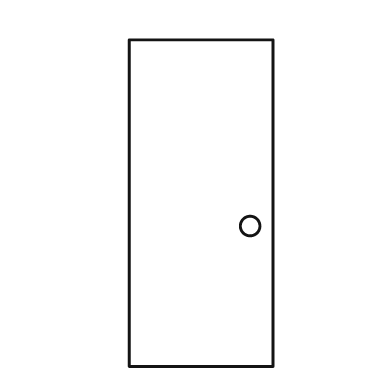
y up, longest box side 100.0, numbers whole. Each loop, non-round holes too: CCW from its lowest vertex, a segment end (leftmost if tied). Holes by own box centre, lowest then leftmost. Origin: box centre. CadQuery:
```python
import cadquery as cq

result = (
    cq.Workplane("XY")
    .moveTo(-22.0, -50.0)
    .lineTo(22.0, -50.0)
    .lineTo(22.0, 50.0)
    .lineTo(-22.0, 50.0)
    .close()
    .moveTo(15.0, -7.0)
    .circle(3.0)
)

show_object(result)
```